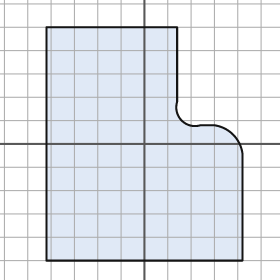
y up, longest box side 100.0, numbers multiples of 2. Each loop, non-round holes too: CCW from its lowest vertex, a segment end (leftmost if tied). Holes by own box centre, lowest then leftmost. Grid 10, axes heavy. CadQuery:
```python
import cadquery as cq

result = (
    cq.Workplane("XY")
    .moveTo(-42.0, -50.0)
    .lineTo(42.0, -50.0)
    .lineTo(42.0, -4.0)
    .threePointArc((38.0, 4.0), (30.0, 8.0))
    .lineTo(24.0, 8.0)
    .threePointArc((16.0, 10.0), (14.0, 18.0))
    .lineTo(14.0, 50.0)
    .lineTo(-42.0, 50.0)
    .close()
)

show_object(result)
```